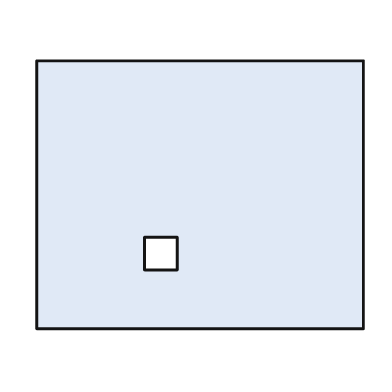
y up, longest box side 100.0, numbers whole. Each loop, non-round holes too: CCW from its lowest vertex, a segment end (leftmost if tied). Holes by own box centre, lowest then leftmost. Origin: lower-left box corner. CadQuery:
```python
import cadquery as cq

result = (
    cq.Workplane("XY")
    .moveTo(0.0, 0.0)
    .lineTo(100.0, 0.0)
    .lineTo(100.0, 82.0)
    .lineTo(0.0, 82.0)
    .close()
    .moveTo(33.0, 18.0)
    .lineTo(43.0, 18.0)
    .lineTo(43.0, 28.0)
    .lineTo(33.0, 28.0)
    .close()
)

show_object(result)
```